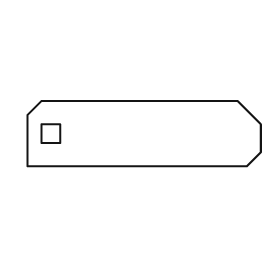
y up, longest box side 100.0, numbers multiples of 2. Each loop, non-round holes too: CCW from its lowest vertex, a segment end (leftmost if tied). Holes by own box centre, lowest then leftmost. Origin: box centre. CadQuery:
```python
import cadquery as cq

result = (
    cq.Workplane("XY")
    .moveTo(-50.0, -14.0)
    .lineTo(44.0, -14.0)
    .lineTo(50.0, -8.0)
    .lineTo(50.0, 4.0)
    .lineTo(40.0, 14.0)
    .lineTo(-44.0, 14.0)
    .lineTo(-50.0, 8.0)
    .close()
    .moveTo(-44.0, -4.0)
    .lineTo(-36.0, -4.0)
    .lineTo(-36.0, 4.0)
    .lineTo(-44.0, 4.0)
    .close()
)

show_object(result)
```